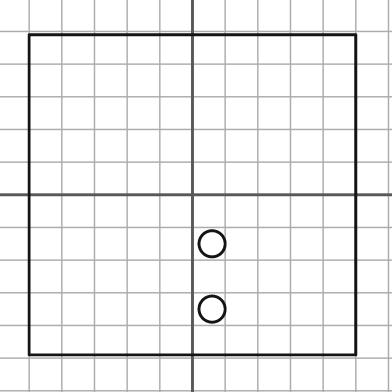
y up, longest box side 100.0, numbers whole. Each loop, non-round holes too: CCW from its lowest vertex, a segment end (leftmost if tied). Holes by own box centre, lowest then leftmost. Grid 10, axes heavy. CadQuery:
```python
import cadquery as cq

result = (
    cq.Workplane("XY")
    .moveTo(-50.0, -49.0)
    .lineTo(50.0, -49.0)
    .lineTo(50.0, 49.0)
    .lineTo(-50.0, 49.0)
    .close()
    .moveTo(6.0, -35.0)
    .circle(4.0)
    .moveTo(6.0, -15.0)
    .circle(4.0)
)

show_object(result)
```